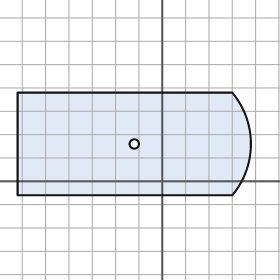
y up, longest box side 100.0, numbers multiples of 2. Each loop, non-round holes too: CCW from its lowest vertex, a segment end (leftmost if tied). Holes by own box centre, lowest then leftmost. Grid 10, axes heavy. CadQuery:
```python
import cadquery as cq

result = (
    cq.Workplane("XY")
    .moveTo(-62.0, -6.0)
    .lineTo(30.0, -6.0)
    .threePointArc((38.0, 16.0), (30.0, 38.0))
    .lineTo(-62.0, 38.0)
    .close()
    .moveTo(-12.0, 16.0)
    .circle(2.0)
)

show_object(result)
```